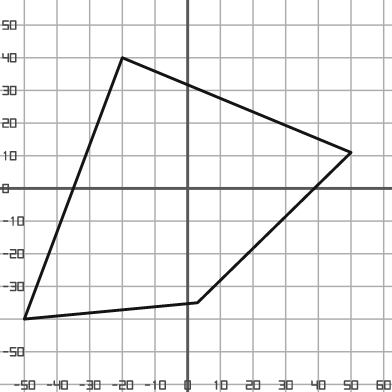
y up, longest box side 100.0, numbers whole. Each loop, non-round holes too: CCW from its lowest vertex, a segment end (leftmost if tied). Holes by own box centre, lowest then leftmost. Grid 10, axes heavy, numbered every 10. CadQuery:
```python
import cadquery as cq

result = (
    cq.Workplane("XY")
    .moveTo(-50.0, -40.0)
    .lineTo(3.0, -35.0)
    .lineTo(50.0, 11.0)
    .lineTo(-20.0, 40.0)
    .close()
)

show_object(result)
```